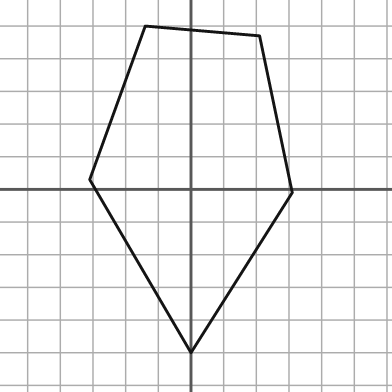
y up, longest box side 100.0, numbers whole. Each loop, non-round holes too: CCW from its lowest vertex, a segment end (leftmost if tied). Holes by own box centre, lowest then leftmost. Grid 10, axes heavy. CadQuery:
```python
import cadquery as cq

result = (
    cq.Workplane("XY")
    .moveTo(0.0, -50.0)
    .lineTo(31.0, -1.0)
    .lineTo(21.0, 47.0)
    .lineTo(-14.0, 50.0)
    .lineTo(-31.0, 3.0)
    .close()
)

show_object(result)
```